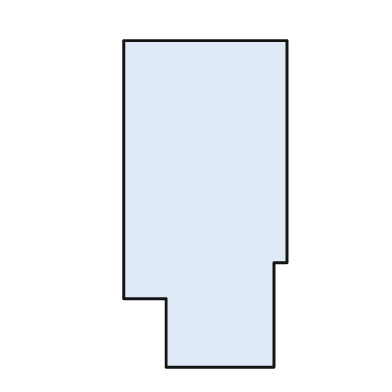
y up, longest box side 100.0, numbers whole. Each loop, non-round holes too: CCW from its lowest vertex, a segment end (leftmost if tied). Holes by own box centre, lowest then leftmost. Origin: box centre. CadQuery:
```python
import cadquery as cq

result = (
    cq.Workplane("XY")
    .moveTo(-12.0, -50.0)
    .lineTo(21.0, -50.0)
    .lineTo(21.0, -18.0)
    .lineTo(25.0, -18.0)
    .lineTo(25.0, 50.0)
    .lineTo(-25.0, 50.0)
    .lineTo(-25.0, -29.0)
    .lineTo(-12.0, -29.0)
    .close()
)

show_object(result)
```